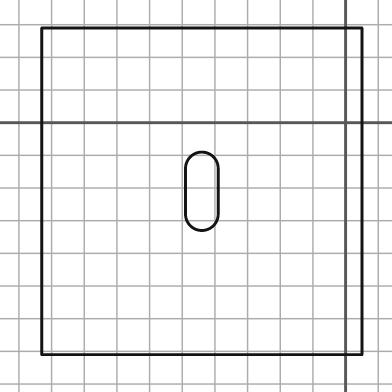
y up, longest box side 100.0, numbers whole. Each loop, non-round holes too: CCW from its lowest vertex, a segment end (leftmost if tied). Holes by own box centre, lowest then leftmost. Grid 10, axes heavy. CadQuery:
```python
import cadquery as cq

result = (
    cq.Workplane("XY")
    .moveTo(-93.0, -71.0)
    .lineTo(5.0, -71.0)
    .lineTo(5.0, 29.0)
    .lineTo(-93.0, 29.0)
    .close()
    .moveTo(-49.0, -28.0)
    .threePointArc((-44.0, -33.0), (-39.0, -28.0))
    .lineTo(-39.0, -14.0)
    .threePointArc((-44.0, -9.0), (-49.0, -14.0))
    .close()
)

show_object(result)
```